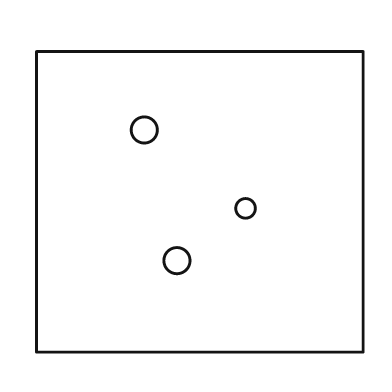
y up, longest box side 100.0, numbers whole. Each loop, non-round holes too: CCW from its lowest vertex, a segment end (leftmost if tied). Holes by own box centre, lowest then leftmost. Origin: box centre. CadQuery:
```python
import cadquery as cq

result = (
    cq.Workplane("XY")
    .moveTo(-50.0, -46.0)
    .lineTo(50.0, -46.0)
    .lineTo(50.0, 46.0)
    .lineTo(-50.0, 46.0)
    .close()
    .moveTo(-7.0, -18.0)
    .circle(4.0)
    .moveTo(14.0, -2.0)
    .circle(3.0)
    .moveTo(-17.0, 22.0)
    .circle(4.0)
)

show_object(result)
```